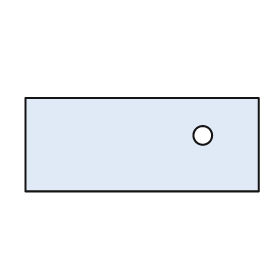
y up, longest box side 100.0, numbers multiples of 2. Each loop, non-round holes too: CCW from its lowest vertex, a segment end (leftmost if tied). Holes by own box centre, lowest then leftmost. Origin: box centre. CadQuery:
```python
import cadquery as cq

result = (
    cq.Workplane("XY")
    .moveTo(-50.0, -20.0)
    .lineTo(50.0, -20.0)
    .lineTo(50.0, 20.0)
    .lineTo(-50.0, 20.0)
    .close()
    .moveTo(26.0, 4.0)
    .circle(4.0)
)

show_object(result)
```